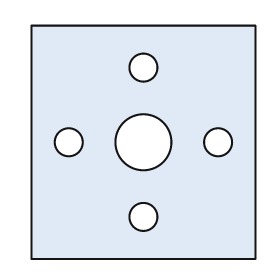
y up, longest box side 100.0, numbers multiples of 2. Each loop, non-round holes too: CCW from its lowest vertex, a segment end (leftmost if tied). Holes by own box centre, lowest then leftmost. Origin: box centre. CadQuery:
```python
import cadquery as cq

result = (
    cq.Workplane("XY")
    .moveTo(-48.0, -50.0)
    .lineTo(48.0, -50.0)
    .lineTo(48.0, 50.0)
    .lineTo(-48.0, 50.0)
    .close()
    .moveTo(0.0, -32.0)
    .circle(6.0)
    .moveTo(-32.0, 0.0)
    .circle(6.0)
    .moveTo(0.0, 0.0)
    .circle(12.0)
    .moveTo(32.0, 0.0)
    .circle(6.0)
    .moveTo(0.0, 32.0)
    .circle(6.0)
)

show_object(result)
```